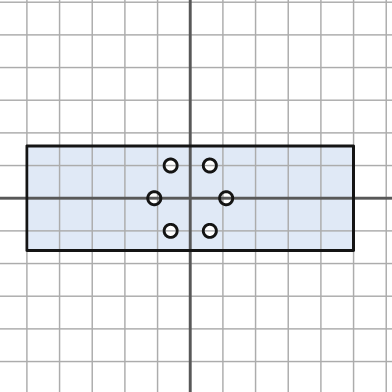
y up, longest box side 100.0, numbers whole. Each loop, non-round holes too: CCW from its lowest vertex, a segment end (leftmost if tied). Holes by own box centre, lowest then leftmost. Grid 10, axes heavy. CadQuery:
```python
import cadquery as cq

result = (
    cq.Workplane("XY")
    .moveTo(-50.0, -16.0)
    .lineTo(50.0, -16.0)
    .lineTo(50.0, 16.0)
    .lineTo(-50.0, 16.0)
    .close()
    .moveTo(-6.0, -10.0)
    .circle(2.0)
    .moveTo(6.0, -10.0)
    .circle(2.0)
    .moveTo(-11.0, 0.0)
    .circle(2.0)
    .moveTo(11.0, 0.0)
    .circle(2.0)
    .moveTo(-6.0, 10.0)
    .circle(2.0)
    .moveTo(6.0, 10.0)
    .circle(2.0)
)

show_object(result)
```